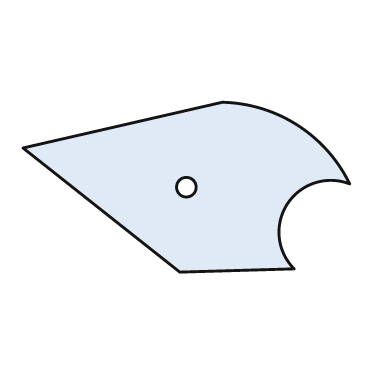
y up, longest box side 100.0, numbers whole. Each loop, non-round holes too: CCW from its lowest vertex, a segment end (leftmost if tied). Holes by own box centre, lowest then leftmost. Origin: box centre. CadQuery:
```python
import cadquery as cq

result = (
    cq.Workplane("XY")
    .moveTo(-2.0, -26.0)
    .lineTo(33.0, -25.0)
    .threePointArc((31.0, -5.0), (50.0, 1.0))
    .threePointArc((34.0, 19.0), (11.0, 26.0))
    .lineTo(-50.0, 12.0)
    .close()
    .moveTo(0.0, 0.0)
    .circle(3.0)
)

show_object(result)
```